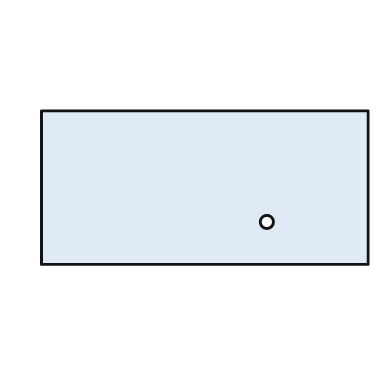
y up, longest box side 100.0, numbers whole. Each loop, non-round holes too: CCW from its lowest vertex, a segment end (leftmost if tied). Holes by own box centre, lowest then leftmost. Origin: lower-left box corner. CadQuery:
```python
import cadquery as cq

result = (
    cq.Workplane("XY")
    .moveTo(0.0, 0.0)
    .lineTo(100.0, 0.0)
    .lineTo(100.0, 47.0)
    .lineTo(0.0, 47.0)
    .close()
    .moveTo(69.0, 13.0)
    .circle(2.0)
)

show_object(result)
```